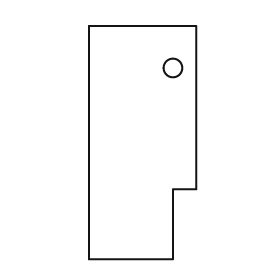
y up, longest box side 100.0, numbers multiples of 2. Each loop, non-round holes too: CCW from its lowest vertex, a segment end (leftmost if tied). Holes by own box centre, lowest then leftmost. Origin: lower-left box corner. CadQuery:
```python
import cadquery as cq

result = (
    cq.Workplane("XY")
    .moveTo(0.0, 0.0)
    .lineTo(36.0, 0.0)
    .lineTo(36.0, 30.0)
    .lineTo(46.0, 30.0)
    .lineTo(46.0, 100.0)
    .lineTo(0.0, 100.0)
    .close()
    .moveTo(36.0, 82.0)
    .circle(4.0)
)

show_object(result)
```